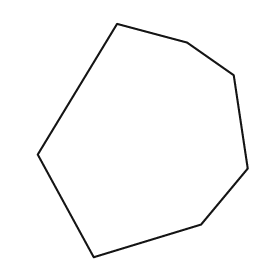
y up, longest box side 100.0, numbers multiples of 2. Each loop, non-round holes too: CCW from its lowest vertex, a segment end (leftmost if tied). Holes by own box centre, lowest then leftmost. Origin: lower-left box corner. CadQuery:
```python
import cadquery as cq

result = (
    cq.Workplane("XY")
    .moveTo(24.0, 0.0)
    .lineTo(70.0, 14.0)
    .lineTo(90.0, 38.0)
    .lineTo(84.0, 78.0)
    .lineTo(64.0, 92.0)
    .lineTo(34.0, 100.0)
    .lineTo(0.0, 44.0)
    .close()
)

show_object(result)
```